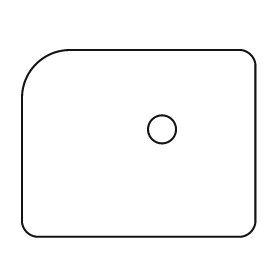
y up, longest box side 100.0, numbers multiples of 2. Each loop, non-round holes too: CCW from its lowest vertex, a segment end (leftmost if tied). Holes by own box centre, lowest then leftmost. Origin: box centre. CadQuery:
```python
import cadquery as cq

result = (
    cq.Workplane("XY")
    .moveTo(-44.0, -40.0)
    .lineTo(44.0, -40.0)
    .threePointArc((48.0, -38.0), (50.0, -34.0))
    .lineTo(50.0, 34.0)
    .threePointArc((48.0, 38.0), (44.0, 40.0))
    .lineTo(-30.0, 40.0)
    .threePointArc((-44.0, 34.0), (-50.0, 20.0))
    .lineTo(-50.0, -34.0)
    .threePointArc((-48.0, -38.0), (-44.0, -40.0))
    .close()
    .moveTo(10.0, 6.0)
    .circle(6.0)
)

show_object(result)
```